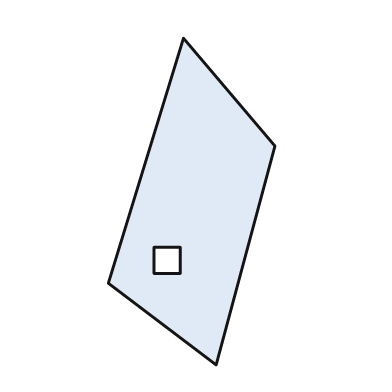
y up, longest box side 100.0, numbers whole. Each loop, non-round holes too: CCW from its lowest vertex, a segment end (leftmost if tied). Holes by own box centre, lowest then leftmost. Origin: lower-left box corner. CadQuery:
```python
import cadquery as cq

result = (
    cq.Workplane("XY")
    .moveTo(33.0, 0.0)
    .lineTo(51.0, 67.0)
    .lineTo(23.0, 100.0)
    .lineTo(0.0, 25.0)
    .close()
    .moveTo(14.0, 28.0)
    .lineTo(22.0, 28.0)
    .lineTo(22.0, 36.0)
    .lineTo(14.0, 36.0)
    .close()
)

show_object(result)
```